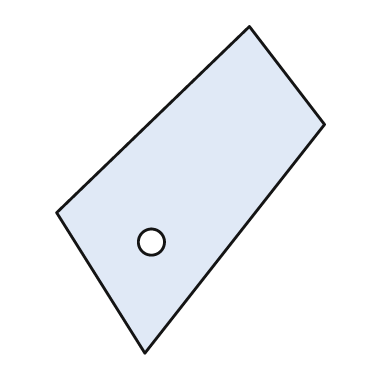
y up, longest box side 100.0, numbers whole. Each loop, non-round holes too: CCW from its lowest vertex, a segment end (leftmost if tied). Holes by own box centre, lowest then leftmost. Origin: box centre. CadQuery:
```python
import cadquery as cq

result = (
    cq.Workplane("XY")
    .moveTo(-14.0, -50.0)
    .lineTo(41.0, 20.0)
    .lineTo(18.0, 50.0)
    .lineTo(-41.0, -7.0)
    .close()
    .moveTo(-12.0, -16.0)
    .circle(4.0)
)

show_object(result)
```